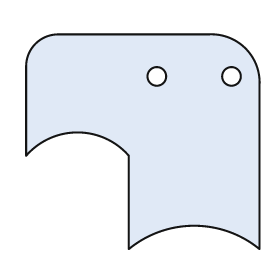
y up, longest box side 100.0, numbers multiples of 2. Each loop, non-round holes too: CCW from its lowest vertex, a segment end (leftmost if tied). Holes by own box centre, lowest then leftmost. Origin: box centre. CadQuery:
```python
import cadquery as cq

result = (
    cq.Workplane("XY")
    .moveTo(-6.0, -46.0)
    .threePointArc((22.0, -36.0), (50.0, -46.0))
    .lineTo(50.0, 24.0)
    .threePointArc((44.0, 40.0), (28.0, 46.0))
    .lineTo(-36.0, 46.0)
    .threePointArc((-46.0, 42.0), (-50.0, 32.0))
    .lineTo(-50.0, -6.0)
    .threePointArc((-28.0, 4.0), (-6.0, -6.0))
    .close()
    .moveTo(6.0, 28.0)
    .circle(4.0)
    .moveTo(38.0, 28.0)
    .circle(4.0)
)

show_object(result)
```